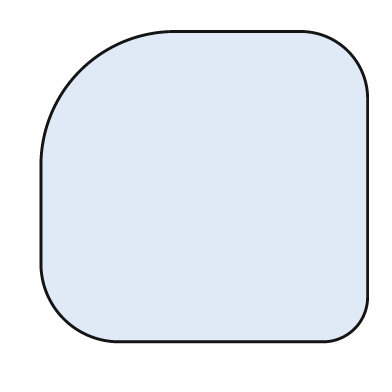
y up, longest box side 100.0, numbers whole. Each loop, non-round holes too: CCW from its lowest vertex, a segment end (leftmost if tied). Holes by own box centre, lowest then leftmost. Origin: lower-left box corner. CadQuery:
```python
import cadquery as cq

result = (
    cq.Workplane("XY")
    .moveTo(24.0, 0.0)
    .lineTo(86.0, 0.0)
    .threePointArc((96.0, 4.0), (100.0, 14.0))
    .lineTo(100.0, 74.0)
    .threePointArc((94.0, 89.0), (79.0, 95.0))
    .lineTo(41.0, 95.0)
    .threePointArc((12.0, 83.0), (0.0, 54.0))
    .lineTo(0.0, 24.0)
    .threePointArc((7.0, 7.0), (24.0, 0.0))
    .close()
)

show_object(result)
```